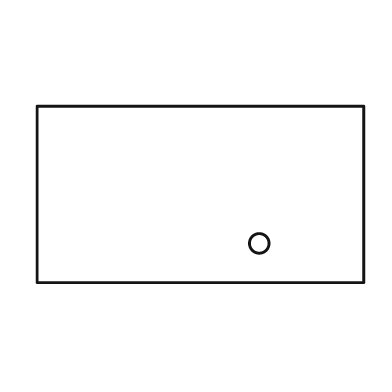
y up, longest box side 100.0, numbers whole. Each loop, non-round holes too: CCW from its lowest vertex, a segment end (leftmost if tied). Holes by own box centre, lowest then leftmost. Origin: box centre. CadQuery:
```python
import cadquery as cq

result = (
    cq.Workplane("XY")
    .moveTo(-50.0, -27.0)
    .lineTo(50.0, -27.0)
    .lineTo(50.0, 27.0)
    .lineTo(-50.0, 27.0)
    .close()
    .moveTo(18.0, -15.0)
    .circle(3.0)
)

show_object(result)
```